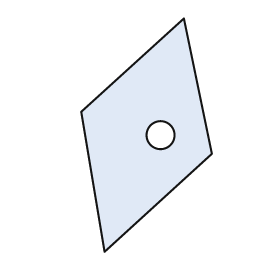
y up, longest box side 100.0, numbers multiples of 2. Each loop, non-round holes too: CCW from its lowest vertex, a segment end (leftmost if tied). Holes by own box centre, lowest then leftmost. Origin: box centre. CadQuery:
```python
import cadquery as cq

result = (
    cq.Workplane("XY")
    .moveTo(-18.0, -50.0)
    .lineTo(28.0, -8.0)
    .lineTo(16.0, 50.0)
    .lineTo(-28.0, 10.0)
    .close()
    .moveTo(6.0, 0.0)
    .circle(6.0)
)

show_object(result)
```